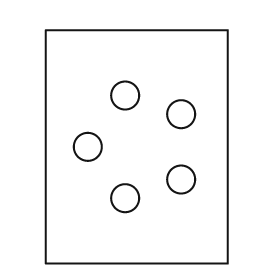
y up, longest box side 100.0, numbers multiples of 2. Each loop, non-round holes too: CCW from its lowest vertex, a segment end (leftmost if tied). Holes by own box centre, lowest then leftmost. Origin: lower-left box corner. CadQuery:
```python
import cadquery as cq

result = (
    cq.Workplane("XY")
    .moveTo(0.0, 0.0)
    .lineTo(78.0, 0.0)
    .lineTo(78.0, 100.0)
    .lineTo(0.0, 100.0)
    .close()
    .moveTo(34.0, 28.0)
    .circle(6.0)
    .moveTo(58.0, 36.0)
    .circle(6.0)
    .moveTo(18.0, 50.0)
    .circle(6.0)
    .moveTo(58.0, 64.0)
    .circle(6.0)
    .moveTo(34.0, 72.0)
    .circle(6.0)
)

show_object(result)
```